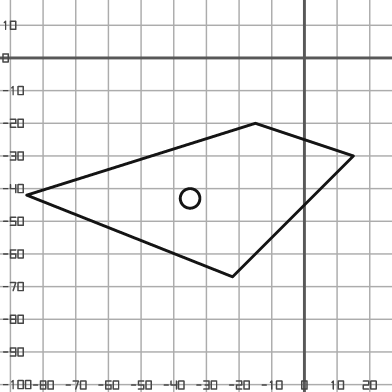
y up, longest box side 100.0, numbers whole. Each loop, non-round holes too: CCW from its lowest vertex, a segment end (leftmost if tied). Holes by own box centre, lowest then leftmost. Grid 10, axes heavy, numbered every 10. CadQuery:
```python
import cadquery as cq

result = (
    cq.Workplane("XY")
    .moveTo(-22.0, -67.0)
    .lineTo(15.0, -30.0)
    .lineTo(-15.0, -20.0)
    .lineTo(-85.0, -42.0)
    .close()
    .moveTo(-35.0, -43.0)
    .circle(3.0)
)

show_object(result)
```